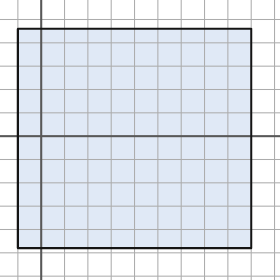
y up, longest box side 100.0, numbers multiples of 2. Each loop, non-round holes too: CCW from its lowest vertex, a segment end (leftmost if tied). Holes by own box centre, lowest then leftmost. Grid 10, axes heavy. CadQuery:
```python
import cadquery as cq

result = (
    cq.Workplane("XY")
    .moveTo(-10.0, -48.0)
    .lineTo(90.0, -48.0)
    .lineTo(90.0, 46.0)
    .lineTo(-10.0, 46.0)
    .close()
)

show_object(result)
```